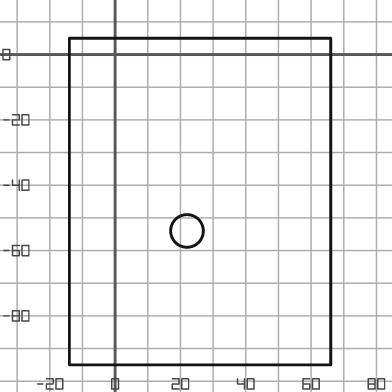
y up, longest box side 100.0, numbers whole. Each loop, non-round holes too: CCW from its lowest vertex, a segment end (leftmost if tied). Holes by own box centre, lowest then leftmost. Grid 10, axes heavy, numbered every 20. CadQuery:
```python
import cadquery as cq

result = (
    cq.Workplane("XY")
    .moveTo(-14.0, -95.0)
    .lineTo(66.0, -95.0)
    .lineTo(66.0, 5.0)
    .lineTo(-14.0, 5.0)
    .close()
    .moveTo(22.0, -54.0)
    .circle(5.0)
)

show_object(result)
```